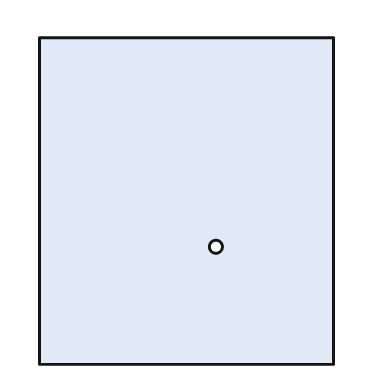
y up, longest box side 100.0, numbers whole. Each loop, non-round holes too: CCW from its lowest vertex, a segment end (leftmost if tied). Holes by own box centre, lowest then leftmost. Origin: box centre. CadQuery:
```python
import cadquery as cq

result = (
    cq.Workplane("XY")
    .moveTo(-45.0, -50.0)
    .lineTo(45.0, -50.0)
    .lineTo(45.0, 50.0)
    .lineTo(-45.0, 50.0)
    .close()
    .moveTo(9.0, -14.0)
    .circle(2.0)
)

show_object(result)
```